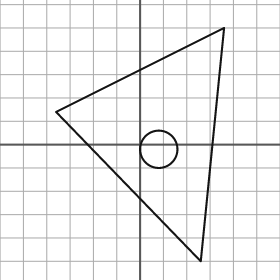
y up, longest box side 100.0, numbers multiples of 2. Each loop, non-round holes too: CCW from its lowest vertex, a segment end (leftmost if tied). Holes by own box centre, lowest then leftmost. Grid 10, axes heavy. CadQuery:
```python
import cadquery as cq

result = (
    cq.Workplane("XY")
    .moveTo(26.0, -50.0)
    .lineTo(36.0, 50.0)
    .lineTo(-36.0, 14.0)
    .close()
    .moveTo(8.0, -2.0)
    .circle(8.0)
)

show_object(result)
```